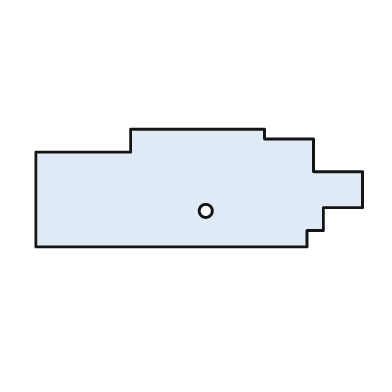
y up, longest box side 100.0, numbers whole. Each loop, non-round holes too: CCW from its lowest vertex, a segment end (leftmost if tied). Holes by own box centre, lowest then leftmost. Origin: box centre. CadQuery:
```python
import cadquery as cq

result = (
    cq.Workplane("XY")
    .moveTo(-50.0, -18.0)
    .lineTo(33.0, -18.0)
    .lineTo(33.0, -13.0)
    .lineTo(38.0, -13.0)
    .lineTo(38.0, -6.0)
    .lineTo(50.0, -6.0)
    .lineTo(50.0, 5.0)
    .lineTo(35.0, 5.0)
    .lineTo(35.0, 15.0)
    .lineTo(20.0, 15.0)
    .lineTo(20.0, 18.0)
    .lineTo(-21.0, 18.0)
    .lineTo(-21.0, 11.0)
    .lineTo(-50.0, 11.0)
    .close()
    .moveTo(2.0, -7.0)
    .circle(2.0)
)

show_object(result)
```